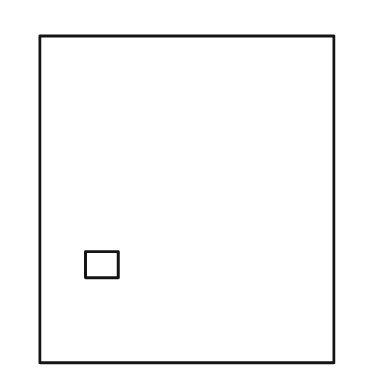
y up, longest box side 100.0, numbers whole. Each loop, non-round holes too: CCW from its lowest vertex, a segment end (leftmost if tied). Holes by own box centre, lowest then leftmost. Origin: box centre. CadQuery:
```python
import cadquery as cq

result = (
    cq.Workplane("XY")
    .moveTo(-45.0, -50.0)
    .lineTo(45.0, -50.0)
    .lineTo(45.0, 50.0)
    .lineTo(-45.0, 50.0)
    .close()
    .moveTo(-31.0, -24.0)
    .lineTo(-21.0, -24.0)
    .lineTo(-21.0, -16.0)
    .lineTo(-31.0, -16.0)
    .close()
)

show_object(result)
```